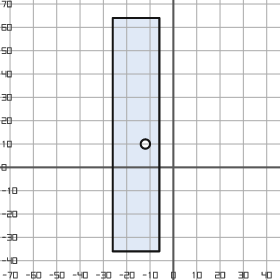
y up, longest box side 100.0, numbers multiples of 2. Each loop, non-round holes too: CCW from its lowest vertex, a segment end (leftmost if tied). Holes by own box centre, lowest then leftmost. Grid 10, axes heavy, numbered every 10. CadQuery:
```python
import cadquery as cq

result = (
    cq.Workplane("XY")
    .moveTo(-26.0, -36.0)
    .lineTo(-6.0, -36.0)
    .lineTo(-6.0, 64.0)
    .lineTo(-26.0, 64.0)
    .close()
    .moveTo(-12.0, 10.0)
    .circle(2.0)
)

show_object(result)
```